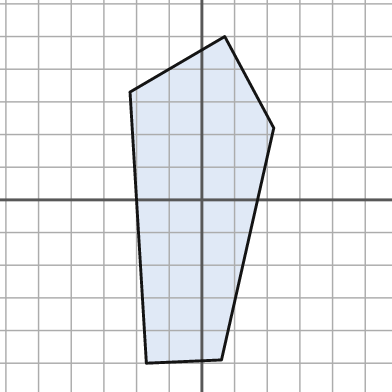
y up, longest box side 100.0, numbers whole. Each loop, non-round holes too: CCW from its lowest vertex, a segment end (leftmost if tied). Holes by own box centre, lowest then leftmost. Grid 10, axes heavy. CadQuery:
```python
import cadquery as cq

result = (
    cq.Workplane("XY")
    .moveTo(-17.0, -50.0)
    .lineTo(6.0, -49.0)
    .lineTo(22.0, 22.0)
    .lineTo(7.0, 50.0)
    .lineTo(-22.0, 33.0)
    .close()
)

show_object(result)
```